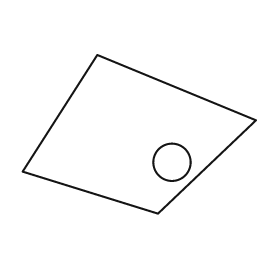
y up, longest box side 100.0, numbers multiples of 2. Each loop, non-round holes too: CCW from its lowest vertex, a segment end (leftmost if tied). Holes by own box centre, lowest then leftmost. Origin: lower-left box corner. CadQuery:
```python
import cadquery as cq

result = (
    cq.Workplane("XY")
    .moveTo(58.0, 0.0)
    .lineTo(100.0, 40.0)
    .lineTo(32.0, 68.0)
    .lineTo(0.0, 18.0)
    .close()
    .moveTo(64.0, 22.0)
    .circle(8.0)
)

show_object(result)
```